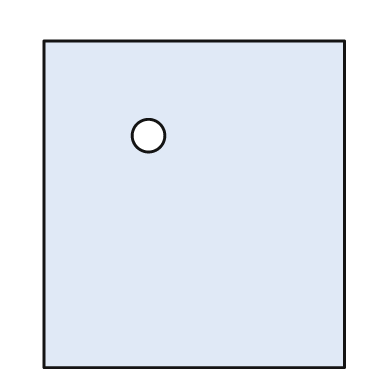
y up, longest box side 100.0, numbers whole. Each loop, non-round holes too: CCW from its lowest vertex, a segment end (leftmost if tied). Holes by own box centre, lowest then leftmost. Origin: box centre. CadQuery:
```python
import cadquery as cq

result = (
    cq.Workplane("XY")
    .moveTo(-46.0, -50.0)
    .lineTo(46.0, -50.0)
    .lineTo(46.0, 50.0)
    .lineTo(-46.0, 50.0)
    .close()
    .moveTo(-14.0, 21.0)
    .circle(5.0)
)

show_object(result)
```